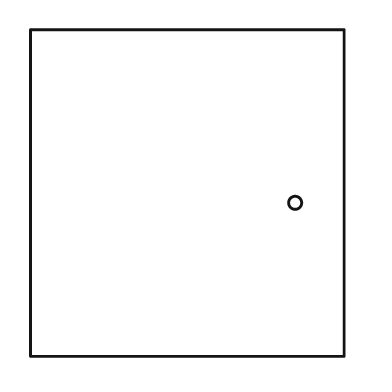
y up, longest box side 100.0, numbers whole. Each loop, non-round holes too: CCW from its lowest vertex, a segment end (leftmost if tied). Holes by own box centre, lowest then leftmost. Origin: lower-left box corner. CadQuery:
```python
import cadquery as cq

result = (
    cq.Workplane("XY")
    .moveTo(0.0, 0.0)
    .lineTo(96.0, 0.0)
    .lineTo(96.0, 100.0)
    .lineTo(0.0, 100.0)
    .close()
    .moveTo(81.0, 47.0)
    .circle(2.0)
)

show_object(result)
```